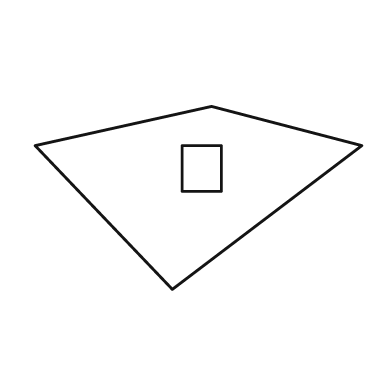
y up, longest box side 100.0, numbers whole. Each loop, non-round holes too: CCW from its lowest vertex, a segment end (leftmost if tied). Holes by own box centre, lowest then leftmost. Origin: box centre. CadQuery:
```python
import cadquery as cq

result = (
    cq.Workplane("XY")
    .moveTo(-8.0, -28.0)
    .lineTo(50.0, 16.0)
    .lineTo(4.0, 28.0)
    .lineTo(-50.0, 16.0)
    .close()
    .moveTo(-5.0, 2.0)
    .lineTo(7.0, 2.0)
    .lineTo(7.0, 16.0)
    .lineTo(-5.0, 16.0)
    .close()
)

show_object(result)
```